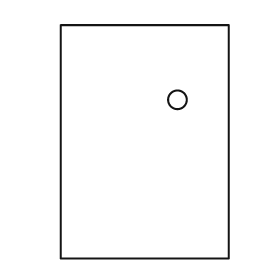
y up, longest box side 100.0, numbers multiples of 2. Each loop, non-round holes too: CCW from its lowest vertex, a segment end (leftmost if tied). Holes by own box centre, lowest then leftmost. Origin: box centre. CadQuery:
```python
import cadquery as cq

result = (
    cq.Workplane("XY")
    .moveTo(-36.0, -50.0)
    .lineTo(36.0, -50.0)
    .lineTo(36.0, 50.0)
    .lineTo(-36.0, 50.0)
    .close()
    .moveTo(14.0, 18.0)
    .circle(4.0)
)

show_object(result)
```